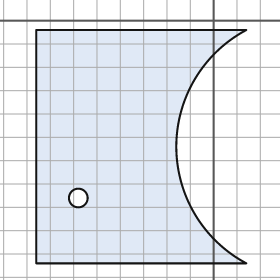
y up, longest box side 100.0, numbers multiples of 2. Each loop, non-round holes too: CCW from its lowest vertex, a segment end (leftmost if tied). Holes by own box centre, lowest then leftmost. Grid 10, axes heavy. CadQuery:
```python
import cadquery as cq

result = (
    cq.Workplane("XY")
    .moveTo(-76.0, -104.0)
    .lineTo(14.0, -104.0)
    .threePointArc((-16.0, -54.0), (14.0, -4.0))
    .lineTo(-76.0, -4.0)
    .close()
    .moveTo(-58.0, -76.0)
    .circle(4.0)
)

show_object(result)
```